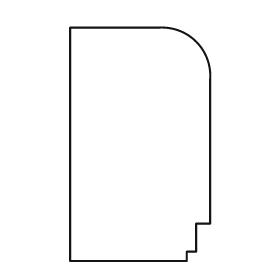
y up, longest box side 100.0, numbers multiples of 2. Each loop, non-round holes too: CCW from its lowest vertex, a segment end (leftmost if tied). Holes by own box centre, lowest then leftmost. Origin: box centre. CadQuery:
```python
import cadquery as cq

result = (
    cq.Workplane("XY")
    .moveTo(-30.0, -50.0)
    .lineTo(20.0, -50.0)
    .lineTo(20.0, -46.0)
    .lineTo(24.0, -46.0)
    .lineTo(24.0, -34.0)
    .lineTo(30.0, -34.0)
    .lineTo(30.0, 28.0)
    .threePointArc((24.0, 44.0), (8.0, 50.0))
    .lineTo(-30.0, 50.0)
    .close()
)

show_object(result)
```